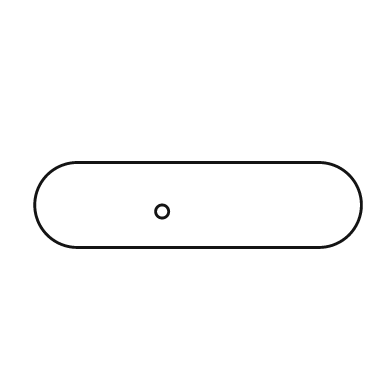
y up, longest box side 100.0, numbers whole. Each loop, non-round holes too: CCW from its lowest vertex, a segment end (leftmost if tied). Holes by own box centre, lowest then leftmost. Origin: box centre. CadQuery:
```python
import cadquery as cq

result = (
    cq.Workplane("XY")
    .moveTo(-37.0, -13.0)
    .lineTo(37.0, -13.0)
    .threePointArc((50.0, 0.0), (37.0, 13.0))
    .lineTo(-37.0, 13.0)
    .threePointArc((-50.0, 0.0), (-37.0, -13.0))
    .close()
    .moveTo(-11.0, -2.0)
    .circle(2.0)
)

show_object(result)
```